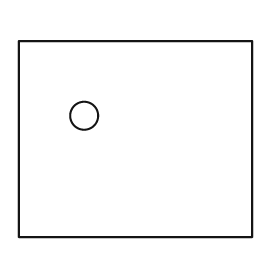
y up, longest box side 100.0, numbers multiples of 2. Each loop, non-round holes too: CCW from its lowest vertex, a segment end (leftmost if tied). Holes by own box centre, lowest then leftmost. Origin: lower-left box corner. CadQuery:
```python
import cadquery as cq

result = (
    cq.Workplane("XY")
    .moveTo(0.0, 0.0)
    .lineTo(100.0, 0.0)
    .lineTo(100.0, 84.0)
    .lineTo(0.0, 84.0)
    .close()
    .moveTo(28.0, 52.0)
    .circle(6.0)
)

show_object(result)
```